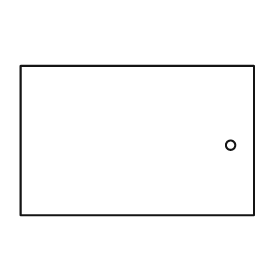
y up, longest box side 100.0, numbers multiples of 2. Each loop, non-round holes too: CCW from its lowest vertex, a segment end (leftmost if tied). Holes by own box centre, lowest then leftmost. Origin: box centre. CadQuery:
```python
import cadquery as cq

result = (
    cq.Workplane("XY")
    .moveTo(-50.0, -32.0)
    .lineTo(50.0, -32.0)
    .lineTo(50.0, 32.0)
    .lineTo(-50.0, 32.0)
    .close()
    .moveTo(40.0, -2.0)
    .circle(2.0)
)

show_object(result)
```